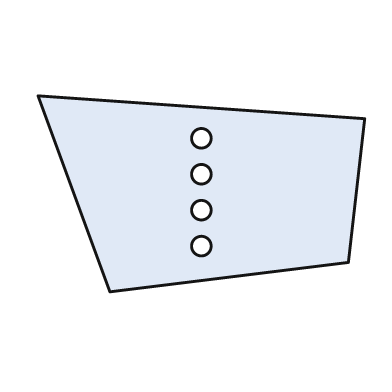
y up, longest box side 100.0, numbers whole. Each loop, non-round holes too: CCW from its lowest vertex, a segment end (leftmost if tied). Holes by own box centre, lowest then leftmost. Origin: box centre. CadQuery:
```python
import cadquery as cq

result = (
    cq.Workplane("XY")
    .moveTo(-28.0, -30.0)
    .lineTo(45.0, -21.0)
    .lineTo(50.0, 23.0)
    .lineTo(-50.0, 30.0)
    .close()
    .moveTo(0.0, -16.0)
    .circle(3.0)
    .moveTo(0.0, -5.0)
    .circle(3.0)
    .moveTo(0.0, 6.0)
    .circle(3.0)
    .moveTo(0.0, 17.0)
    .circle(3.0)
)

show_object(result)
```